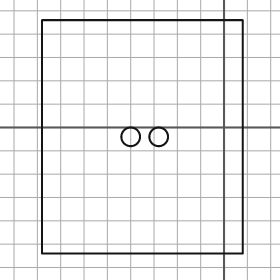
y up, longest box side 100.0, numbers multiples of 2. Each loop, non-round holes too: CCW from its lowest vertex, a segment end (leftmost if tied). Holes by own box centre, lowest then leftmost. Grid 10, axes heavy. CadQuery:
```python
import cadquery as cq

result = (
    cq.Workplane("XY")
    .moveTo(-78.0, -54.0)
    .lineTo(8.0, -54.0)
    .lineTo(8.0, 46.0)
    .lineTo(-78.0, 46.0)
    .close()
    .moveTo(-40.0, -4.0)
    .circle(4.0)
    .moveTo(-28.0, -4.0)
    .circle(4.0)
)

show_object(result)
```